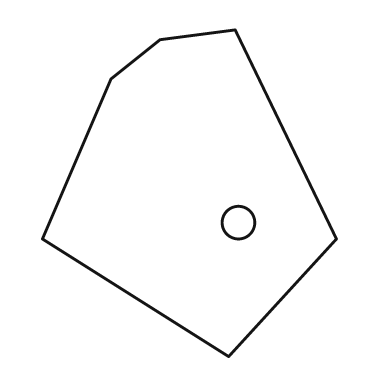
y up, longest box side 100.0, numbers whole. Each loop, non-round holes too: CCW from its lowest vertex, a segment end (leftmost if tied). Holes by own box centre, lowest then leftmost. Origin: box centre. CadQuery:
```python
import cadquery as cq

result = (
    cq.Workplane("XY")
    .moveTo(12.0, -50.0)
    .lineTo(45.0, -14.0)
    .lineTo(14.0, 50.0)
    .lineTo(-9.0, 47.0)
    .lineTo(-24.0, 35.0)
    .lineTo(-45.0, -14.0)
    .close()
    .moveTo(15.0, -9.0)
    .circle(5.0)
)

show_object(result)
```